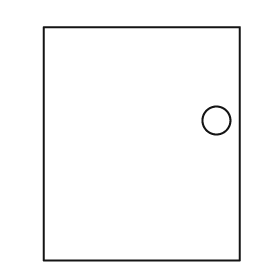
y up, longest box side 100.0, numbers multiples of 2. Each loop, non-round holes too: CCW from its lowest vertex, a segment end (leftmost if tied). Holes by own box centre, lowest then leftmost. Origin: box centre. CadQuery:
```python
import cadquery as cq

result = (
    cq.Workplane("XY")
    .moveTo(-42.0, -50.0)
    .lineTo(42.0, -50.0)
    .lineTo(42.0, 50.0)
    .lineTo(-42.0, 50.0)
    .close()
    .moveTo(32.0, 10.0)
    .circle(6.0)
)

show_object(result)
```